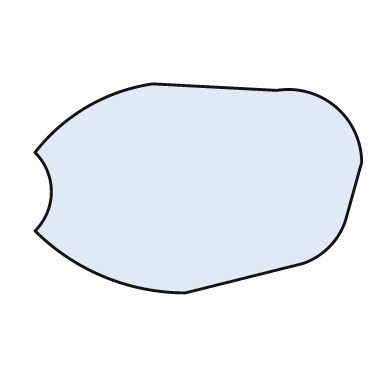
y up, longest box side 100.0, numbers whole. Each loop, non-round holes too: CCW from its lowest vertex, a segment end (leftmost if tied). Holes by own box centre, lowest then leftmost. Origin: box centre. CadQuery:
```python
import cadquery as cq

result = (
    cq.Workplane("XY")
    .moveTo(-4.0, -32.0)
    .lineTo(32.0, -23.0)
    .threePointArc((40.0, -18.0), (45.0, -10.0))
    .lineTo(50.0, 8.0)
    .threePointArc((42.0, 25.0), (24.0, 30.0))
    .lineTo(-14.0, 32.0)
    .threePointArc((-34.0, 25.0), (-50.0, 11.0))
    .threePointArc((-45.0, -1.0), (-50.0, -13.0))
    .threePointArc((-29.0, -27.0), (-4.0, -32.0))
    .close()
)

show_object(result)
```